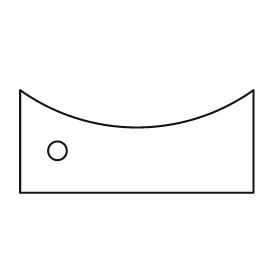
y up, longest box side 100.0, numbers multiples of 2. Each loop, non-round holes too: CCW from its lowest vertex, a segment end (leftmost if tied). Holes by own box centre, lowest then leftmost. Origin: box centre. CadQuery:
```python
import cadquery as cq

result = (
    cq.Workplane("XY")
    .moveTo(-50.0, -22.0)
    .lineTo(50.0, -22.0)
    .lineTo(50.0, 22.0)
    .threePointArc((0.0, 6.0), (-50.0, 22.0))
    .close()
    .moveTo(-34.0, -4.0)
    .circle(4.0)
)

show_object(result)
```